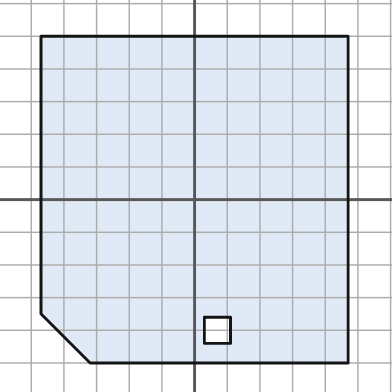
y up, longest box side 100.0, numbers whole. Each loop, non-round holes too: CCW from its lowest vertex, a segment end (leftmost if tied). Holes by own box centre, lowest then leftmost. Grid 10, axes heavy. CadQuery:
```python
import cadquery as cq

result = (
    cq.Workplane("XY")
    .moveTo(-32.0, -50.0)
    .lineTo(47.0, -50.0)
    .lineTo(47.0, 50.0)
    .lineTo(-47.0, 50.0)
    .lineTo(-47.0, -35.0)
    .close()
    .moveTo(3.0, -44.0)
    .lineTo(11.0, -44.0)
    .lineTo(11.0, -36.0)
    .lineTo(3.0, -36.0)
    .close()
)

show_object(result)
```